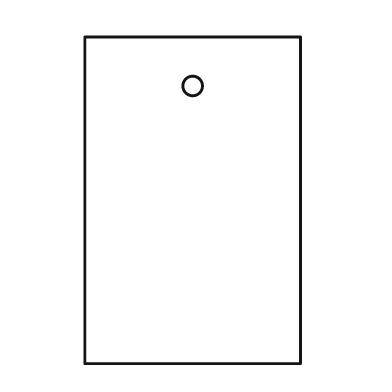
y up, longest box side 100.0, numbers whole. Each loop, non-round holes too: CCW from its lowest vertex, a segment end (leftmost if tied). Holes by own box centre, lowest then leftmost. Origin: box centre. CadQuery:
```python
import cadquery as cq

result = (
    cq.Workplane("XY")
    .moveTo(-33.0, -50.0)
    .lineTo(33.0, -50.0)
    .lineTo(33.0, 50.0)
    .lineTo(-33.0, 50.0)
    .close()
    .moveTo(0.0, 35.0)
    .circle(3.0)
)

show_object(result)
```